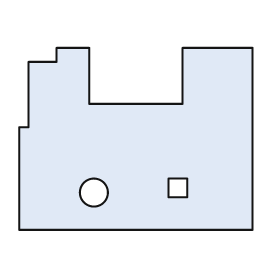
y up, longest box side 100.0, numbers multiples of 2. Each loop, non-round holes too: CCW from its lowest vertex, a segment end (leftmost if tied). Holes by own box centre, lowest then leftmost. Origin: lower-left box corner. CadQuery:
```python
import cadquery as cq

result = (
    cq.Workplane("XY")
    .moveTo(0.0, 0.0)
    .lineTo(100.0, 0.0)
    .lineTo(100.0, 78.0)
    .lineTo(70.0, 78.0)
    .lineTo(70.0, 54.0)
    .lineTo(30.0, 54.0)
    .lineTo(30.0, 78.0)
    .lineTo(16.0, 78.0)
    .lineTo(16.0, 72.0)
    .lineTo(4.0, 72.0)
    .lineTo(4.0, 44.0)
    .lineTo(0.0, 44.0)
    .close()
    .moveTo(32.0, 16.0)
    .circle(6.0)
    .moveTo(64.0, 14.0)
    .lineTo(72.0, 14.0)
    .lineTo(72.0, 22.0)
    .lineTo(64.0, 22.0)
    .close()
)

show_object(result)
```